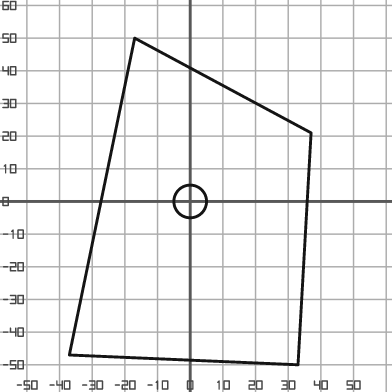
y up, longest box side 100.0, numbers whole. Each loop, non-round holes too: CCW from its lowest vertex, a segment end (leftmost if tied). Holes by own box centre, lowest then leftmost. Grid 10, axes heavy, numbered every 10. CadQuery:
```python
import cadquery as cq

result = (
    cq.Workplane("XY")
    .moveTo(33.0, -50.0)
    .lineTo(37.0, 21.0)
    .lineTo(-17.0, 50.0)
    .lineTo(-37.0, -47.0)
    .close()
    .moveTo(0.0, 0.0)
    .circle(5.0)
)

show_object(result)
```